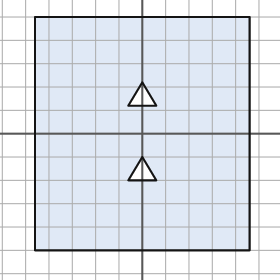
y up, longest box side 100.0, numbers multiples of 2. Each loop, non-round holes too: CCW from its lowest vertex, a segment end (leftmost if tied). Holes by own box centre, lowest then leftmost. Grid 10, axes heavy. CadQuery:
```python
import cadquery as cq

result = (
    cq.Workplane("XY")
    .moveTo(-46.0, -50.0)
    .lineTo(46.0, -50.0)
    .lineTo(46.0, 50.0)
    .lineTo(-46.0, 50.0)
    .close()
    .moveTo(-6.0, -20.0)
    .lineTo(6.0, -20.0)
    .lineTo(0.0, -10.0)
    .close()
    .moveTo(-6.0, 12.0)
    .lineTo(6.0, 12.0)
    .lineTo(0.0, 22.0)
    .close()
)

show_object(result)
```